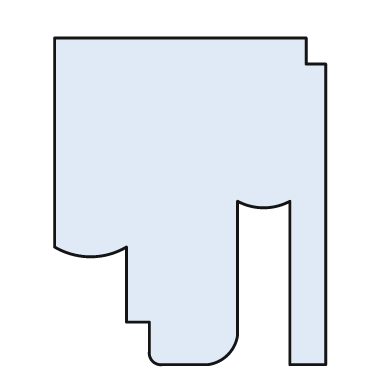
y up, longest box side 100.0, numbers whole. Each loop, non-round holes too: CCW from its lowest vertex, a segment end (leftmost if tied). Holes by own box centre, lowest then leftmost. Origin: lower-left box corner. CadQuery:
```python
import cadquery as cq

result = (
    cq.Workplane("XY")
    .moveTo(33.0, 0.0)
    .lineTo(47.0, 0.0)
    .threePointArc((53.0, 3.0), (56.0, 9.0))
    .lineTo(56.0, 50.0)
    .threePointArc((64.0, 48.0), (72.0, 50.0))
    .lineTo(72.0, 0.0)
    .lineTo(83.0, 0.0)
    .lineTo(83.0, 92.0)
    .lineTo(77.0, 92.0)
    .lineTo(77.0, 100.0)
    .lineTo(0.0, 100.0)
    .lineTo(0.0, 36.0)
    .threePointArc((11.0, 33.0), (22.0, 36.0))
    .lineTo(22.0, 13.0)
    .lineTo(29.0, 13.0)
    .lineTo(29.0, 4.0)
    .threePointArc((30.0, 1.0), (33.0, 0.0))
    .close()
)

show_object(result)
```